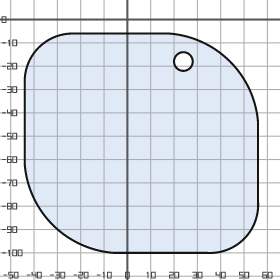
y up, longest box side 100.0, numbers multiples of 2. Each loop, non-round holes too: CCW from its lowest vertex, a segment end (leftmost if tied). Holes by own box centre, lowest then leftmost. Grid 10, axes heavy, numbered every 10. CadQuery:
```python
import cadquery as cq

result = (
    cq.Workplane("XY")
    .moveTo(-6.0, -100.0)
    .lineTo(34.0, -100.0)
    .threePointArc((50.0, -94.0), (56.0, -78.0))
    .lineTo(56.0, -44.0)
    .threePointArc((44.0, -18.0), (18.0, -6.0))
    .lineTo(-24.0, -6.0)
    .threePointArc((-38.0, -12.0), (-44.0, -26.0))
    .lineTo(-44.0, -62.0)
    .threePointArc((-32.0, -88.0), (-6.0, -100.0))
    .close()
    .moveTo(24.0, -18.0)
    .circle(4.0)
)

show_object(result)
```